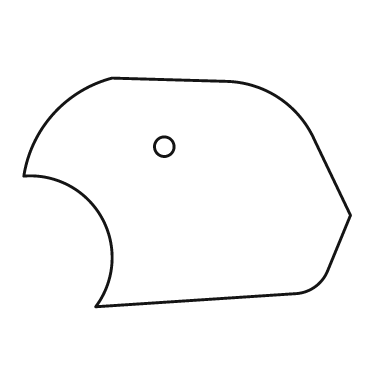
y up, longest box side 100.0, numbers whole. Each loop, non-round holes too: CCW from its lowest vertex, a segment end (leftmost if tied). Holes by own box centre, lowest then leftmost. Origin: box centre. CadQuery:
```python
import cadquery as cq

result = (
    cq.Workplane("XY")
    .moveTo(-28.0, -35.0)
    .lineTo(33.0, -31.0)
    .threePointArc((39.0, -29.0), (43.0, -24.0))
    .lineTo(50.0, -7.0)
    .lineTo(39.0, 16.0)
    .threePointArc((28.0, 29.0), (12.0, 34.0))
    .lineTo(-23.0, 35.0)
    .threePointArc((-41.0, 24.0), (-50.0, 5.0))
    .threePointArc((-26.0, -8.0), (-28.0, -35.0))
    .close()
    .moveTo(-7.0, 14.0)
    .circle(3.0)
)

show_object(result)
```